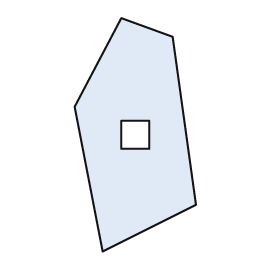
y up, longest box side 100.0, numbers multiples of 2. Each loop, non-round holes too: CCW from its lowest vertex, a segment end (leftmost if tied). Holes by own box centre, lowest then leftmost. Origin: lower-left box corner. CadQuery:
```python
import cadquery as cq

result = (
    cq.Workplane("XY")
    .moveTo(12.0, 0.0)
    .lineTo(52.0, 20.0)
    .lineTo(42.0, 92.0)
    .lineTo(20.0, 100.0)
    .lineTo(0.0, 62.0)
    .close()
    .moveTo(20.0, 44.0)
    .lineTo(32.0, 44.0)
    .lineTo(32.0, 56.0)
    .lineTo(20.0, 56.0)
    .close()
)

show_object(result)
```